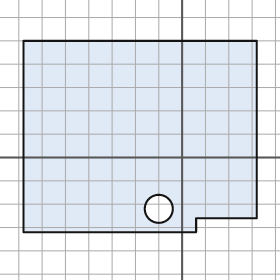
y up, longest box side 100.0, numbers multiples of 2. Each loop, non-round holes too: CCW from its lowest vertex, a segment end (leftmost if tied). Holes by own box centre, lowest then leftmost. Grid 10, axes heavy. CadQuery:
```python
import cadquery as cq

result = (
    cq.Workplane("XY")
    .moveTo(-68.0, -32.0)
    .lineTo(6.0, -32.0)
    .lineTo(6.0, -26.0)
    .lineTo(32.0, -26.0)
    .lineTo(32.0, 50.0)
    .lineTo(-68.0, 50.0)
    .close()
    .moveTo(-10.0, -22.0)
    .circle(6.0)
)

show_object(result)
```